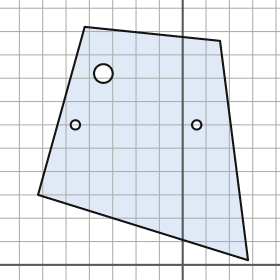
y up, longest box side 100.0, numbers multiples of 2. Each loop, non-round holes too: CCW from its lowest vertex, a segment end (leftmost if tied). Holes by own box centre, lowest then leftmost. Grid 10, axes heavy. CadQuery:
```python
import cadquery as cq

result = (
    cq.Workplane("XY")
    .moveTo(28.0, 2.0)
    .lineTo(16.0, 96.0)
    .lineTo(-42.0, 102.0)
    .lineTo(-62.0, 30.0)
    .close()
    .moveTo(-46.0, 60.0)
    .circle(2.0)
    .moveTo(6.0, 60.0)
    .circle(2.0)
    .moveTo(-34.0, 82.0)
    .circle(4.0)
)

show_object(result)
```